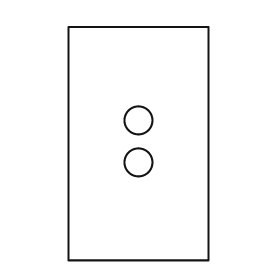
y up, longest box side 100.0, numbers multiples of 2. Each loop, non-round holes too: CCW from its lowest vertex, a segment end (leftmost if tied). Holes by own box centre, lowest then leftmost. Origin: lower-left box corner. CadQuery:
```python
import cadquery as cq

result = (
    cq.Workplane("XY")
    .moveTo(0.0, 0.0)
    .lineTo(60.0, 0.0)
    .lineTo(60.0, 100.0)
    .lineTo(0.0, 100.0)
    .close()
    .moveTo(30.0, 42.0)
    .circle(6.0)
    .moveTo(30.0, 60.0)
    .circle(6.0)
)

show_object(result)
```